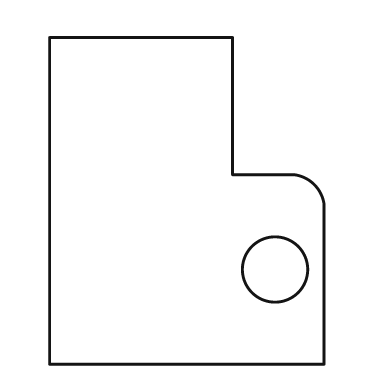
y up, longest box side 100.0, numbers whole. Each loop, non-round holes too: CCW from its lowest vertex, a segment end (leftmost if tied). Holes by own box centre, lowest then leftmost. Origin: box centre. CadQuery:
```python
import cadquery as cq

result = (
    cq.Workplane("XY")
    .moveTo(-42.0, -50.0)
    .lineTo(42.0, -50.0)
    .lineTo(42.0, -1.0)
    .threePointArc((39.0, 5.0), (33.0, 8.0))
    .lineTo(14.0, 8.0)
    .lineTo(14.0, 50.0)
    .lineTo(-42.0, 50.0)
    .close()
    .moveTo(27.0, -21.0)
    .circle(10.0)
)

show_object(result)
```